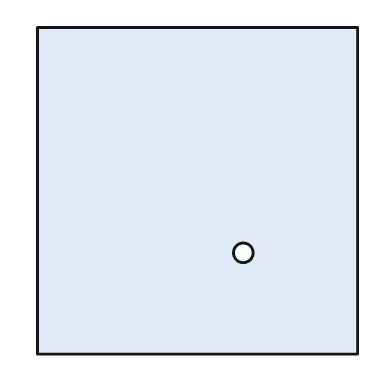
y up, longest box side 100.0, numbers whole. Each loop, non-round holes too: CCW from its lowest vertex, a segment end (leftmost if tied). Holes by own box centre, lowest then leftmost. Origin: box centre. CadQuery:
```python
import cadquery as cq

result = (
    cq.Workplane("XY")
    .moveTo(-49.0, -50.0)
    .lineTo(49.0, -50.0)
    .lineTo(49.0, 50.0)
    .lineTo(-49.0, 50.0)
    .close()
    .moveTo(14.0, -19.0)
    .circle(3.0)
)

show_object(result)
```